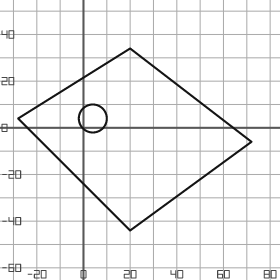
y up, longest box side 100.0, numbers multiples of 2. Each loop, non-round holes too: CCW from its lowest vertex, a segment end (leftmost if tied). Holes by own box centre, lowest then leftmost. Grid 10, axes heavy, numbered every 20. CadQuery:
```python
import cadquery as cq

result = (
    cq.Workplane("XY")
    .moveTo(20.0, -44.0)
    .lineTo(72.0, -6.0)
    .lineTo(20.0, 34.0)
    .lineTo(-28.0, 4.0)
    .close()
    .moveTo(4.0, 4.0)
    .circle(6.0)
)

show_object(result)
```